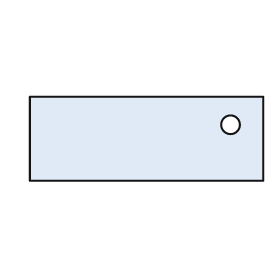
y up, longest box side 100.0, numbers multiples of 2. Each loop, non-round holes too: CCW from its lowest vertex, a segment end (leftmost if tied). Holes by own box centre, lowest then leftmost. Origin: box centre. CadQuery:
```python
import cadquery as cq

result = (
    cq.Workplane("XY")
    .moveTo(-50.0, -18.0)
    .lineTo(50.0, -18.0)
    .lineTo(50.0, 18.0)
    .lineTo(-50.0, 18.0)
    .close()
    .moveTo(36.0, 6.0)
    .circle(4.0)
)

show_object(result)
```